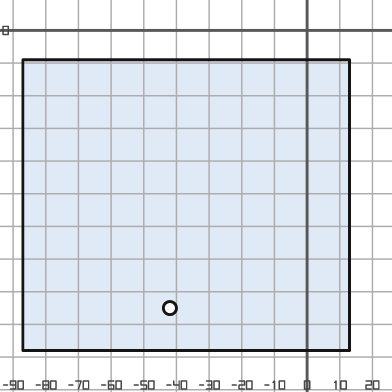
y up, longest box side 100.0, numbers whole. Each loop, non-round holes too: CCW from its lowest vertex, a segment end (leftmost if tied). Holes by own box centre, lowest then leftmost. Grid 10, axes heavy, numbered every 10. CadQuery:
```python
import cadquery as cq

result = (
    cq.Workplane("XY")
    .moveTo(-87.0, -98.0)
    .lineTo(13.0, -98.0)
    .lineTo(13.0, -9.0)
    .lineTo(-87.0, -9.0)
    .close()
    .moveTo(-42.0, -85.0)
    .circle(2.0)
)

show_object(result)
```